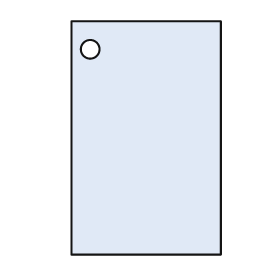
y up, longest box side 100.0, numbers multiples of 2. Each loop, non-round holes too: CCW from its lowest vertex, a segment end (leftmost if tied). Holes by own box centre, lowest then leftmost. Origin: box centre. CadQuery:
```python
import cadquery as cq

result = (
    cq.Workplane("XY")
    .moveTo(-32.0, -50.0)
    .lineTo(32.0, -50.0)
    .lineTo(32.0, 50.0)
    .lineTo(-32.0, 50.0)
    .close()
    .moveTo(-24.0, 38.0)
    .circle(4.0)
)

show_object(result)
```